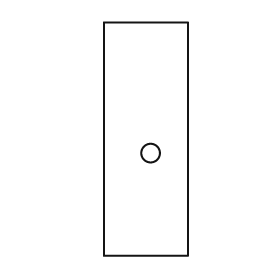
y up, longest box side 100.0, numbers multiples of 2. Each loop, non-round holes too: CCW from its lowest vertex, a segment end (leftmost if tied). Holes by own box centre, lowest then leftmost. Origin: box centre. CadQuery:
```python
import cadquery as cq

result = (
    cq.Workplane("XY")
    .moveTo(-18.0, -50.0)
    .lineTo(18.0, -50.0)
    .lineTo(18.0, 50.0)
    .lineTo(-18.0, 50.0)
    .close()
    .moveTo(2.0, -6.0)
    .circle(4.0)
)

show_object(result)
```